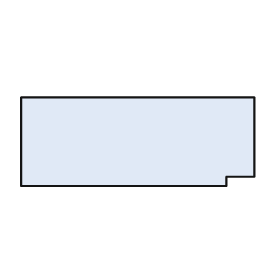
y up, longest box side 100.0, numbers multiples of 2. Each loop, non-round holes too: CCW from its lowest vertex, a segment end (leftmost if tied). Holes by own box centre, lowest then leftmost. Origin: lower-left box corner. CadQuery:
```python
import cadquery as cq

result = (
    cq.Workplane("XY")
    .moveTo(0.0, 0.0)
    .lineTo(88.0, 0.0)
    .lineTo(88.0, 4.0)
    .lineTo(100.0, 4.0)
    .lineTo(100.0, 38.0)
    .lineTo(0.0, 38.0)
    .close()
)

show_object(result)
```